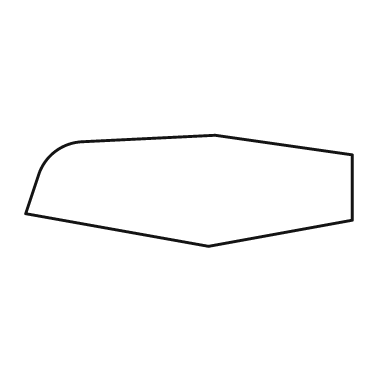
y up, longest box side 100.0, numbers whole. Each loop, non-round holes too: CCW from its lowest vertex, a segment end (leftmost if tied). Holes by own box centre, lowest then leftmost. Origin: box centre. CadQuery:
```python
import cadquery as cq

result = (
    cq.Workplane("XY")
    .moveTo(6.0, -17.0)
    .lineTo(50.0, -9.0)
    .lineTo(50.0, 11.0)
    .lineTo(8.0, 17.0)
    .lineTo(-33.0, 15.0)
    .threePointArc((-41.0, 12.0), (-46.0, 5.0))
    .lineTo(-50.0, -7.0)
    .close()
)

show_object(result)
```